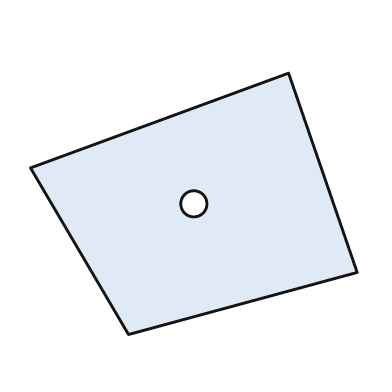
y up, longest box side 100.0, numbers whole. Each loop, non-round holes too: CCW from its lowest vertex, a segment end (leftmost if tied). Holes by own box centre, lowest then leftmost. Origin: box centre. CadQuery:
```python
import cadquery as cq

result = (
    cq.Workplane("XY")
    .moveTo(-20.0, -40.0)
    .lineTo(50.0, -21.0)
    .lineTo(29.0, 40.0)
    .lineTo(-50.0, 11.0)
    .close()
    .moveTo(0.0, 0.0)
    .circle(4.0)
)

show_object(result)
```